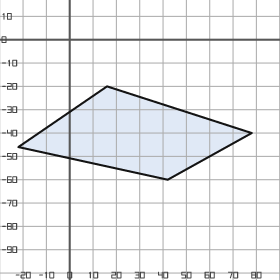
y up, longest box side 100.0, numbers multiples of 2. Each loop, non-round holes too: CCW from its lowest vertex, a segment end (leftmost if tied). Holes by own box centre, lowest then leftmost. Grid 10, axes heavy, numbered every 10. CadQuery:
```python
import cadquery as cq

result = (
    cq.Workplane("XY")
    .moveTo(42.0, -60.0)
    .lineTo(78.0, -40.0)
    .lineTo(16.0, -20.0)
    .lineTo(-22.0, -46.0)
    .close()
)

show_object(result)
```